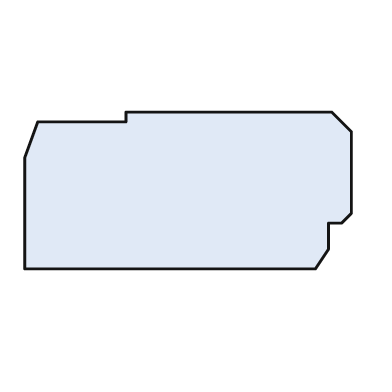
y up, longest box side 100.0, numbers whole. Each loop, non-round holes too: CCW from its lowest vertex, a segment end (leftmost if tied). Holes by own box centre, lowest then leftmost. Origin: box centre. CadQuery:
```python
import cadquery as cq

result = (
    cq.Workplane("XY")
    .moveTo(-50.0, -24.0)
    .lineTo(39.0, -24.0)
    .lineTo(43.0, -18.0)
    .lineTo(43.0, -10.0)
    .lineTo(47.0, -10.0)
    .lineTo(50.0, -7.0)
    .lineTo(50.0, 18.0)
    .lineTo(44.0, 24.0)
    .lineTo(-19.0, 24.0)
    .lineTo(-19.0, 21.0)
    .lineTo(-46.0, 21.0)
    .lineTo(-50.0, 10.0)
    .close()
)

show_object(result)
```